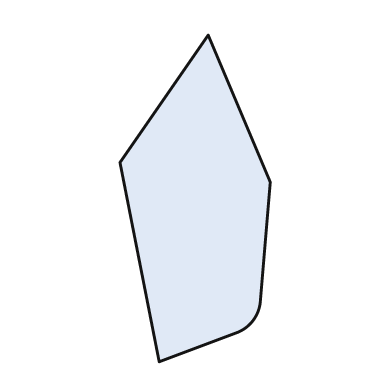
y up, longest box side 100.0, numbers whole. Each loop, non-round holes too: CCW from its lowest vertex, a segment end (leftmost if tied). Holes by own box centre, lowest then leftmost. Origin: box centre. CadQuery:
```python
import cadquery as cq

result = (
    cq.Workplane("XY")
    .moveTo(-11.0, -50.0)
    .lineTo(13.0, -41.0)
    .threePointArc((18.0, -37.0), (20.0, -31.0))
    .lineTo(23.0, 5.0)
    .lineTo(4.0, 50.0)
    .lineTo(-23.0, 11.0)
    .close()
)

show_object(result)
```